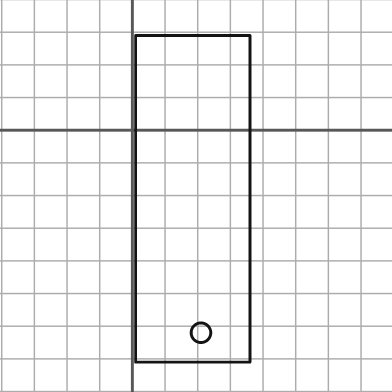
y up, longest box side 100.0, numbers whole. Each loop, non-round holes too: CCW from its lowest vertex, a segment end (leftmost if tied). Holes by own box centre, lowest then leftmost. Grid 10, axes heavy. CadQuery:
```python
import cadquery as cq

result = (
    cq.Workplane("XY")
    .moveTo(1.0, -71.0)
    .lineTo(36.0, -71.0)
    .lineTo(36.0, 29.0)
    .lineTo(1.0, 29.0)
    .close()
    .moveTo(21.0, -62.0)
    .circle(3.0)
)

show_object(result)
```